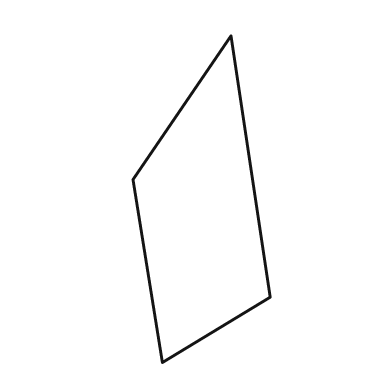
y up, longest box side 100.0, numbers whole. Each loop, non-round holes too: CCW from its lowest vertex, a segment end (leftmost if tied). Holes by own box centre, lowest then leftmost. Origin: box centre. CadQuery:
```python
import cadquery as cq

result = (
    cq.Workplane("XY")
    .moveTo(-12.0, -50.0)
    .lineTo(21.0, -30.0)
    .lineTo(9.0, 50.0)
    .lineTo(-21.0, 6.0)
    .close()
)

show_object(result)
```